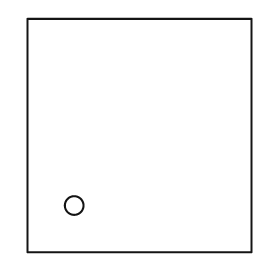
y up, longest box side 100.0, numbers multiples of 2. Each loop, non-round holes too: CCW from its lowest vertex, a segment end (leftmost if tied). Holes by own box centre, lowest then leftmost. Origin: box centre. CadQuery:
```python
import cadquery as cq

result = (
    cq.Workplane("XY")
    .moveTo(-48.0, -50.0)
    .lineTo(48.0, -50.0)
    .lineTo(48.0, 50.0)
    .lineTo(-48.0, 50.0)
    .close()
    .moveTo(-28.0, -30.0)
    .circle(4.0)
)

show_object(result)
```